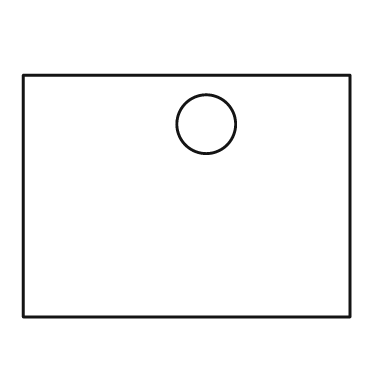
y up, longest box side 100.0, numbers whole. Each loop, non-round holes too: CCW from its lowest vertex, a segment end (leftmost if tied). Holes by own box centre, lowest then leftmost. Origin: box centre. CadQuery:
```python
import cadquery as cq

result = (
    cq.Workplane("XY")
    .moveTo(-50.0, -37.0)
    .lineTo(50.0, -37.0)
    .lineTo(50.0, 37.0)
    .lineTo(-50.0, 37.0)
    .close()
    .moveTo(6.0, 22.0)
    .circle(9.0)
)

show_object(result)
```